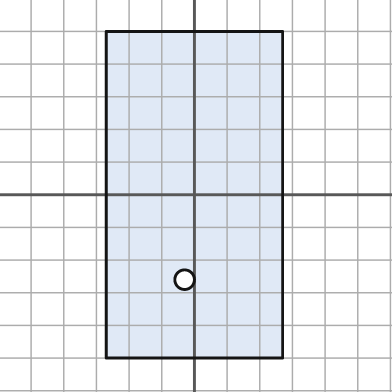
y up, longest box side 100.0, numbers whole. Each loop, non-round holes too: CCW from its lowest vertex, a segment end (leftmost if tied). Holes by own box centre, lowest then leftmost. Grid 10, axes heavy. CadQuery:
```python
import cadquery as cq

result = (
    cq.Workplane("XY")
    .moveTo(-27.0, -50.0)
    .lineTo(27.0, -50.0)
    .lineTo(27.0, 50.0)
    .lineTo(-27.0, 50.0)
    .close()
    .moveTo(-3.0, -26.0)
    .circle(3.0)
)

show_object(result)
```